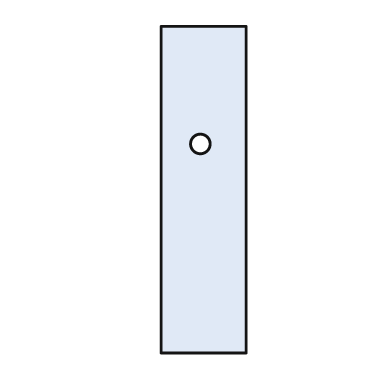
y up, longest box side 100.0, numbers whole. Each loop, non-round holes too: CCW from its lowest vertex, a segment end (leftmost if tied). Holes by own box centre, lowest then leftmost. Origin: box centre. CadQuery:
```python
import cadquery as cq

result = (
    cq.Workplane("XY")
    .moveTo(-13.0, -50.0)
    .lineTo(13.0, -50.0)
    .lineTo(13.0, 50.0)
    .lineTo(-13.0, 50.0)
    .close()
    .moveTo(-1.0, 14.0)
    .circle(3.0)
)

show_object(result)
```